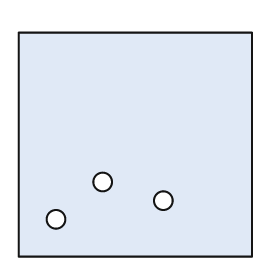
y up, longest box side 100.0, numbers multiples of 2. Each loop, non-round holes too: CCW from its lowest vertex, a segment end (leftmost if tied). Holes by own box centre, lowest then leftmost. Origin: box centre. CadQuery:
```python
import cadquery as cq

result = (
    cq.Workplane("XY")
    .moveTo(-50.0, -48.0)
    .lineTo(50.0, -48.0)
    .lineTo(50.0, 48.0)
    .lineTo(-50.0, 48.0)
    .close()
    .moveTo(-34.0, -32.0)
    .circle(4.0)
    .moveTo(12.0, -24.0)
    .circle(4.0)
    .moveTo(-14.0, -16.0)
    .circle(4.0)
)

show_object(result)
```